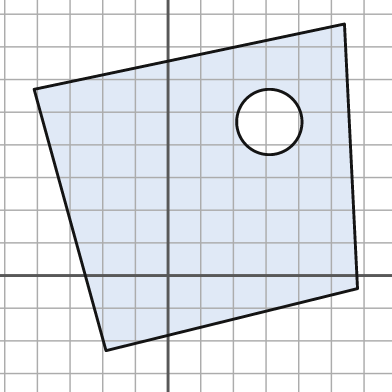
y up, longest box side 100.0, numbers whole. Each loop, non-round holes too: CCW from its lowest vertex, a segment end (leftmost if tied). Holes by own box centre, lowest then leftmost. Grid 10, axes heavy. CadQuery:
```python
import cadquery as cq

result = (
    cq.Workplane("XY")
    .moveTo(-19.0, -23.0)
    .lineTo(58.0, -4.0)
    .lineTo(54.0, 77.0)
    .lineTo(-41.0, 57.0)
    .close()
    .moveTo(31.0, 47.0)
    .circle(10.0)
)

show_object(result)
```